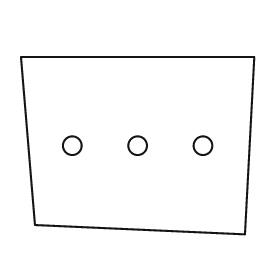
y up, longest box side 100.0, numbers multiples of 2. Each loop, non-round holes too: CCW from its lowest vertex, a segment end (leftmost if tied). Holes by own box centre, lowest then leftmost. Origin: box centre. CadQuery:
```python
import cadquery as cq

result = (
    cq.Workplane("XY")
    .moveTo(46.0, -38.0)
    .lineTo(50.0, 38.0)
    .lineTo(-50.0, 38.0)
    .lineTo(-44.0, -34.0)
    .close()
    .moveTo(-28.0, 0.0)
    .circle(4.0)
    .moveTo(0.0, 0.0)
    .circle(4.0)
    .moveTo(28.0, 0.0)
    .circle(4.0)
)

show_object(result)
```